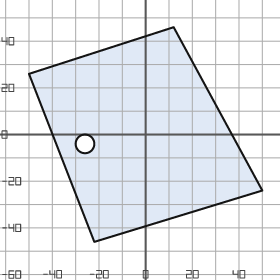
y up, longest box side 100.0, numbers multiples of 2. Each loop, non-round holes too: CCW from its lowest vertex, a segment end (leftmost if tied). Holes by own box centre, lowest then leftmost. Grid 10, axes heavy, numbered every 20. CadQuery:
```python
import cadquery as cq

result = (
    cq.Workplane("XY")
    .moveTo(-22.0, -46.0)
    .lineTo(50.0, -24.0)
    .lineTo(12.0, 46.0)
    .lineTo(-50.0, 26.0)
    .close()
    .moveTo(-26.0, -4.0)
    .circle(4.0)
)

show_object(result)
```